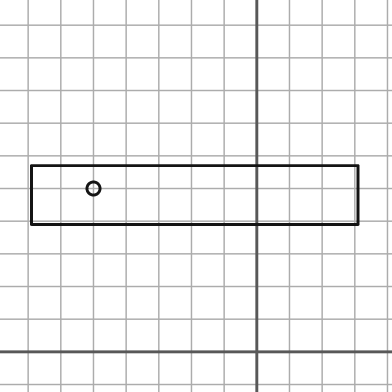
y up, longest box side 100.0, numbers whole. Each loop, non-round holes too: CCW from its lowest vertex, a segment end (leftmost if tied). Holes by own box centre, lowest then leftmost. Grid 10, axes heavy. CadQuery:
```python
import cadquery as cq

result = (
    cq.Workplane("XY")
    .moveTo(-69.0, 39.0)
    .lineTo(31.0, 39.0)
    .lineTo(31.0, 57.0)
    .lineTo(-69.0, 57.0)
    .close()
    .moveTo(-50.0, 50.0)
    .circle(2.0)
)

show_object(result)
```